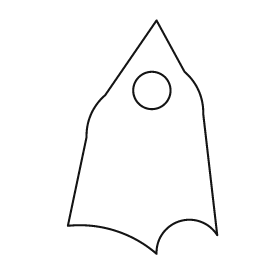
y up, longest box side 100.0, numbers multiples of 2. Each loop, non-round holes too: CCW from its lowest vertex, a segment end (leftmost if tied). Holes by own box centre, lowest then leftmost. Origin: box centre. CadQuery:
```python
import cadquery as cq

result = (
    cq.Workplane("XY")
    .moveTo(6.0, -50.0)
    .threePointArc((16.0, -36.0), (32.0, -42.0))
    .lineTo(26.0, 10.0)
    .threePointArc((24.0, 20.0), (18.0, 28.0))
    .lineTo(6.0, 50.0)
    .lineTo(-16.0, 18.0)
    .threePointArc((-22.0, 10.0), (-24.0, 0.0))
    .lineTo(-32.0, -38.0)
    .threePointArc((-12.0, -40.0), (6.0, -50.0))
    .close()
    .moveTo(4.0, 20.0)
    .circle(8.0)
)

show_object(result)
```